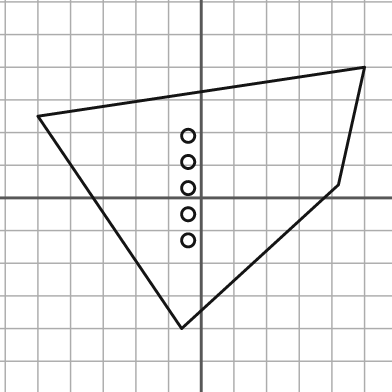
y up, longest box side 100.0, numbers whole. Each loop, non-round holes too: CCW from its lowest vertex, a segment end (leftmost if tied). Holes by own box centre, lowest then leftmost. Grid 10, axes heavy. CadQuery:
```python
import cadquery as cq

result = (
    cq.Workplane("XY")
    .moveTo(-6.0, -40.0)
    .lineTo(42.0, 4.0)
    .lineTo(50.0, 40.0)
    .lineTo(-50.0, 25.0)
    .close()
    .moveTo(-4.0, -13.0)
    .circle(2.0)
    .moveTo(-4.0, -5.0)
    .circle(2.0)
    .moveTo(-4.0, 3.0)
    .circle(2.0)
    .moveTo(-4.0, 11.0)
    .circle(2.0)
    .moveTo(-4.0, 19.0)
    .circle(2.0)
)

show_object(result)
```